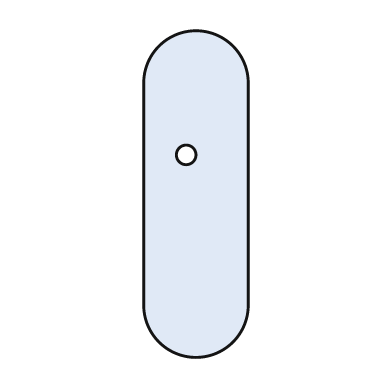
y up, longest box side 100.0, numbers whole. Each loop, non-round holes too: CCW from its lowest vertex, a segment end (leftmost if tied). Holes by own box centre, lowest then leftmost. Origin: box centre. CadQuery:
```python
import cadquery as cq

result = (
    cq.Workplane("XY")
    .moveTo(-16.0, -34.0)
    .threePointArc((0.0, -50.0), (16.0, -34.0))
    .lineTo(16.0, 34.0)
    .threePointArc((0.0, 50.0), (-16.0, 34.0))
    .close()
    .moveTo(-3.0, 12.0)
    .circle(3.0)
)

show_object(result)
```